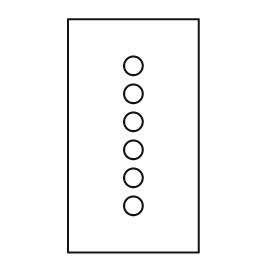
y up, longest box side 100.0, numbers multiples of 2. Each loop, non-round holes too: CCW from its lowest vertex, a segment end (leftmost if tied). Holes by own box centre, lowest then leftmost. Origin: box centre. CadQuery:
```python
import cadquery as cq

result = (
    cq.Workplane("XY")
    .moveTo(-28.0, -50.0)
    .lineTo(28.0, -50.0)
    .lineTo(28.0, 50.0)
    .lineTo(-28.0, 50.0)
    .close()
    .moveTo(0.0, -30.0)
    .circle(4.0)
    .moveTo(0.0, -18.0)
    .circle(4.0)
    .moveTo(0.0, -6.0)
    .circle(4.0)
    .moveTo(0.0, 6.0)
    .circle(4.0)
    .moveTo(0.0, 18.0)
    .circle(4.0)
    .moveTo(0.0, 30.0)
    .circle(4.0)
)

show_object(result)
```